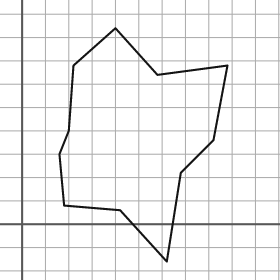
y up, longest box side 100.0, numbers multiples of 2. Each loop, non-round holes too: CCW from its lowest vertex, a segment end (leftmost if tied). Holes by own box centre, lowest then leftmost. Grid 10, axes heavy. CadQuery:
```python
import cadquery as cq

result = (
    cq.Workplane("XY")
    .moveTo(62.0, -16.0)
    .lineTo(68.0, 22.0)
    .lineTo(82.0, 36.0)
    .lineTo(88.0, 68.0)
    .lineTo(58.0, 64.0)
    .lineTo(40.0, 84.0)
    .lineTo(22.0, 68.0)
    .lineTo(20.0, 40.0)
    .lineTo(16.0, 30.0)
    .lineTo(18.0, 8.0)
    .lineTo(42.0, 6.0)
    .close()
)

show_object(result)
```